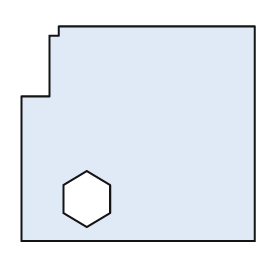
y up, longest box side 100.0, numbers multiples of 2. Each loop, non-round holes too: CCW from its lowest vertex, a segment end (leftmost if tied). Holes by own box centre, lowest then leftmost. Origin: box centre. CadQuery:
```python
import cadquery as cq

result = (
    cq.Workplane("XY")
    .moveTo(-50.0, -46.0)
    .lineTo(50.0, -46.0)
    .lineTo(50.0, 46.0)
    .lineTo(-34.0, 46.0)
    .lineTo(-34.0, 42.0)
    .lineTo(-38.0, 42.0)
    .lineTo(-38.0, 16.0)
    .lineTo(-50.0, 16.0)
    .close()
    .moveTo(-22.0, -40.0)
    .lineTo(-12.0, -34.0)
    .lineTo(-12.0, -22.0)
    .lineTo(-22.0, -16.0)
    .lineTo(-32.0, -22.0)
    .lineTo(-32.0, -34.0)
    .close()
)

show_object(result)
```